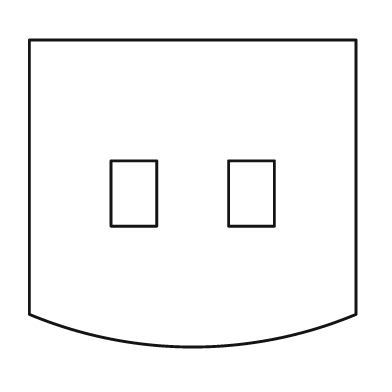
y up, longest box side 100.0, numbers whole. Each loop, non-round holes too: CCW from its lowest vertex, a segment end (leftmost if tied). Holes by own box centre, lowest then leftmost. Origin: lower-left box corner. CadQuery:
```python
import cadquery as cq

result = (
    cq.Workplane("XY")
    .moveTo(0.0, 10.0)
    .threePointArc((50.0, 0.0), (100.0, 10.0))
    .lineTo(100.0, 94.0)
    .lineTo(0.0, 94.0)
    .close()
    .moveTo(25.0, 37.0)
    .lineTo(39.0, 37.0)
    .lineTo(39.0, 57.0)
    .lineTo(25.0, 57.0)
    .close()
    .moveTo(61.0, 37.0)
    .lineTo(75.0, 37.0)
    .lineTo(75.0, 57.0)
    .lineTo(61.0, 57.0)
    .close()
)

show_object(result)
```